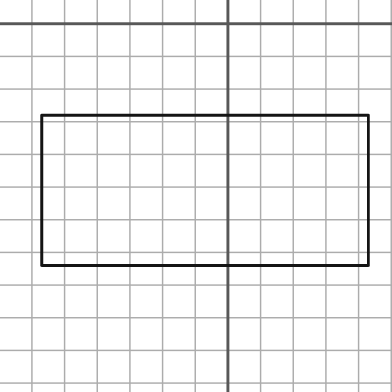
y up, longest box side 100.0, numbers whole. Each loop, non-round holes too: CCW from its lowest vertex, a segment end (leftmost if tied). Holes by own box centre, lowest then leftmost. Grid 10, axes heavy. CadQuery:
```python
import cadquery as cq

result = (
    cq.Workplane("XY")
    .moveTo(-57.0, -74.0)
    .lineTo(43.0, -74.0)
    .lineTo(43.0, -28.0)
    .lineTo(-57.0, -28.0)
    .close()
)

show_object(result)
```